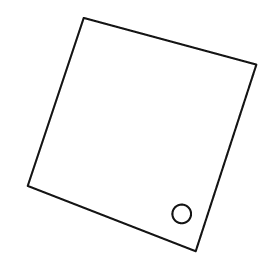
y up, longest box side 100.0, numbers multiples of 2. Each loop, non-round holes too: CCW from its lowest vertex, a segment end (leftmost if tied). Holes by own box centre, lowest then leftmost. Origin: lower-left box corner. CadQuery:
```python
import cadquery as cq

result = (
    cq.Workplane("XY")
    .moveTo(72.0, 0.0)
    .lineTo(98.0, 80.0)
    .lineTo(24.0, 100.0)
    .lineTo(0.0, 28.0)
    .close()
    .moveTo(66.0, 16.0)
    .circle(4.0)
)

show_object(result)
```